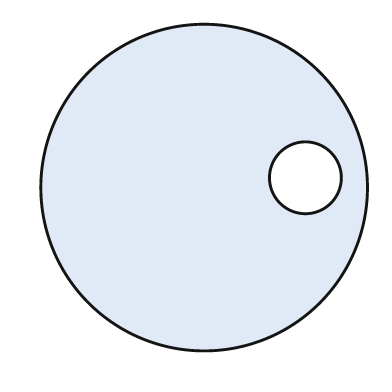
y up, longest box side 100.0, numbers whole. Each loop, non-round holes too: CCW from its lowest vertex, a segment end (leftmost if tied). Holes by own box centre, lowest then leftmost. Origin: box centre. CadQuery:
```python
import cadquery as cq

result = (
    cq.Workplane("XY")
    .moveTo(0.0, 0.0)
    .circle(50.0)
    .moveTo(31.0, 3.0)
    .circle(11.0)
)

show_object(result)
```